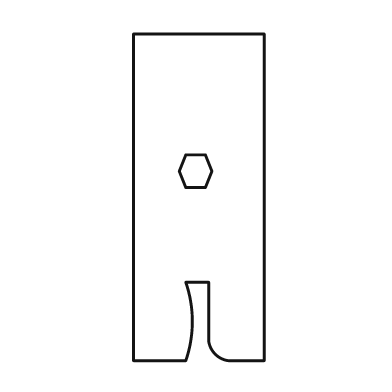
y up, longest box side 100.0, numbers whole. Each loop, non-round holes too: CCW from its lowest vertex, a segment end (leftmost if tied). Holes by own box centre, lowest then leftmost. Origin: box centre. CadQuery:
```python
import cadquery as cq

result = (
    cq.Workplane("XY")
    .moveTo(-20.0, -50.0)
    .lineTo(-4.0, -50.0)
    .threePointArc((-2.0, -38.0), (-4.0, -26.0))
    .lineTo(3.0, -26.0)
    .lineTo(3.0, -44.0)
    .threePointArc((5.0, -48.0), (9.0, -50.0))
    .lineTo(20.0, -50.0)
    .lineTo(20.0, 50.0)
    .lineTo(-20.0, 50.0)
    .close()
    .moveTo(-4.0, 3.0)
    .lineTo(2.0, 3.0)
    .lineTo(4.0, 8.0)
    .lineTo(2.0, 13.0)
    .lineTo(-4.0, 13.0)
    .lineTo(-6.0, 8.0)
    .close()
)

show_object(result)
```